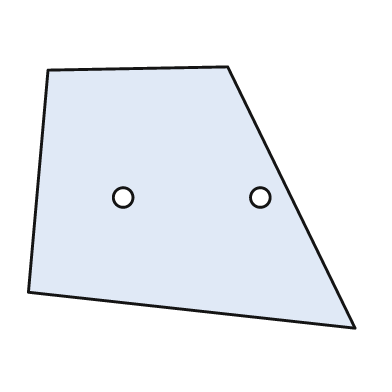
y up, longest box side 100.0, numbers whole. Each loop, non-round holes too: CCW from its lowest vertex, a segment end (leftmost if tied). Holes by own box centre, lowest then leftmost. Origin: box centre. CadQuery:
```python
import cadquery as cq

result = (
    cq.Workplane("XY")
    .moveTo(50.0, -40.0)
    .lineTo(11.0, 40.0)
    .lineTo(-44.0, 39.0)
    .lineTo(-50.0, -29.0)
    .close()
    .moveTo(-21.0, 0.0)
    .circle(3.0)
    .moveTo(21.0, 0.0)
    .circle(3.0)
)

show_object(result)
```